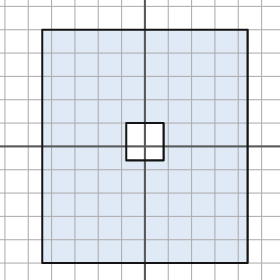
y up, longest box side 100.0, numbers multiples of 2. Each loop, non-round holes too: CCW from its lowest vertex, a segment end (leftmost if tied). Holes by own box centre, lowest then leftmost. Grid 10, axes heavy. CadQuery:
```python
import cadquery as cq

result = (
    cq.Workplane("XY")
    .moveTo(-44.0, -50.0)
    .lineTo(44.0, -50.0)
    .lineTo(44.0, 50.0)
    .lineTo(-44.0, 50.0)
    .close()
    .moveTo(-8.0, -6.0)
    .lineTo(8.0, -6.0)
    .lineTo(8.0, 10.0)
    .lineTo(-8.0, 10.0)
    .close()
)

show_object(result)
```